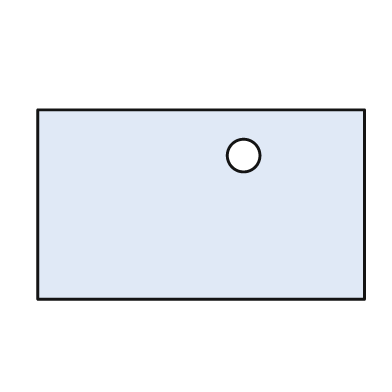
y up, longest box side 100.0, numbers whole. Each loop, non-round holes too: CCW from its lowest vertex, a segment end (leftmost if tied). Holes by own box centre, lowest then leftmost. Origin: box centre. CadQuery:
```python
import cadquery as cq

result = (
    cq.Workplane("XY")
    .moveTo(-50.0, -29.0)
    .lineTo(50.0, -29.0)
    .lineTo(50.0, 29.0)
    .lineTo(-50.0, 29.0)
    .close()
    .moveTo(13.0, 15.0)
    .circle(5.0)
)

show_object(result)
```